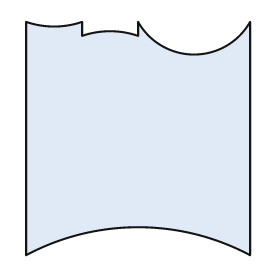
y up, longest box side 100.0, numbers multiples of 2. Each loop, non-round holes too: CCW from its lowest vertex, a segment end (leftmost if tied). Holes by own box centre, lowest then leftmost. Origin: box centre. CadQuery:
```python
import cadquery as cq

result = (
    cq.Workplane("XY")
    .moveTo(-48.0, -50.0)
    .threePointArc((0.0, -38.0), (48.0, -50.0))
    .lineTo(48.0, 50.0)
    .threePointArc((24.0, 36.0), (0.0, 50.0))
    .lineTo(0.0, 44.0)
    .threePointArc((-12.0, 46.0), (-24.0, 44.0))
    .lineTo(-24.0, 50.0)
    .threePointArc((-36.0, 48.0), (-48.0, 50.0))
    .close()
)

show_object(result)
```